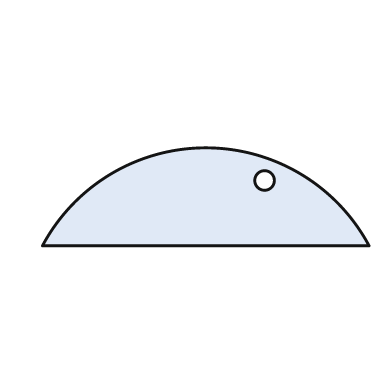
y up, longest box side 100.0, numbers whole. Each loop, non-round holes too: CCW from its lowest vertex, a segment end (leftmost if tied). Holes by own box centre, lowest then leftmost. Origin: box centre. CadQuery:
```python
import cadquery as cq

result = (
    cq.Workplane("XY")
    .moveTo(-50.0, -15.0)
    .lineTo(50.0, -15.0)
    .threePointArc((0.0, 15.0), (-50.0, -15.0))
    .close()
    .moveTo(18.0, 5.0)
    .circle(3.0)
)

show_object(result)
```